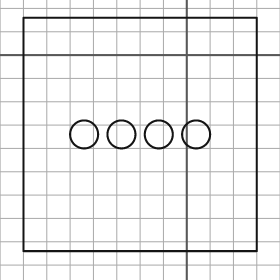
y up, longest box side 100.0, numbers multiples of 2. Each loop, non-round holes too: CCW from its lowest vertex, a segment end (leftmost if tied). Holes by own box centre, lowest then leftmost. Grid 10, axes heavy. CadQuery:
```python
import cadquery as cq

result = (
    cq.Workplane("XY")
    .moveTo(-70.0, -84.0)
    .lineTo(30.0, -84.0)
    .lineTo(30.0, 16.0)
    .lineTo(-70.0, 16.0)
    .close()
    .moveTo(-44.0, -34.0)
    .circle(6.0)
    .moveTo(-28.0, -34.0)
    .circle(6.0)
    .moveTo(-12.0, -34.0)
    .circle(6.0)
    .moveTo(4.0, -34.0)
    .circle(6.0)
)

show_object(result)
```